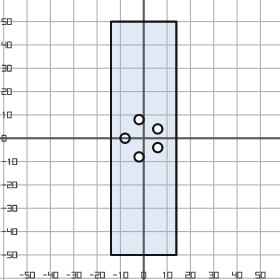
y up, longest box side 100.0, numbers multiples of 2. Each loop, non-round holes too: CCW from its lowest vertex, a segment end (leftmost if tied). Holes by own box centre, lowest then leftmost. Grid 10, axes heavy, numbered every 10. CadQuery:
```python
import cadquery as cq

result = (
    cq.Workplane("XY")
    .moveTo(-14.0, -50.0)
    .lineTo(14.0, -50.0)
    .lineTo(14.0, 50.0)
    .lineTo(-14.0, 50.0)
    .close()
    .moveTo(-2.0, -8.0)
    .circle(2.0)
    .moveTo(6.0, -4.0)
    .circle(2.0)
    .moveTo(-8.0, 0.0)
    .circle(2.0)
    .moveTo(6.0, 4.0)
    .circle(2.0)
    .moveTo(-2.0, 8.0)
    .circle(2.0)
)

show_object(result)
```